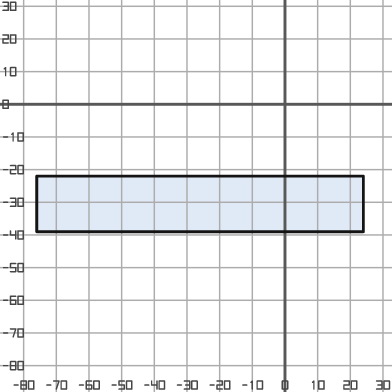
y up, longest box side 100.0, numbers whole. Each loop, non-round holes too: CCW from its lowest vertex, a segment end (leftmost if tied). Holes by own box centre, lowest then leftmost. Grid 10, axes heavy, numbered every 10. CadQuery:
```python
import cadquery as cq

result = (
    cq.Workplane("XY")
    .moveTo(-76.0, -39.0)
    .lineTo(24.0, -39.0)
    .lineTo(24.0, -22.0)
    .lineTo(-76.0, -22.0)
    .close()
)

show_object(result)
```